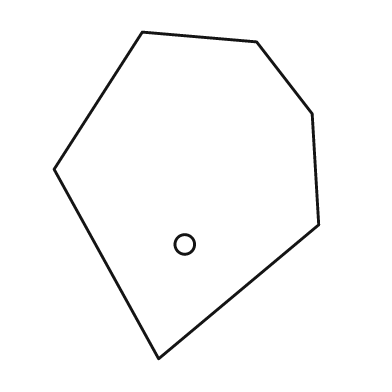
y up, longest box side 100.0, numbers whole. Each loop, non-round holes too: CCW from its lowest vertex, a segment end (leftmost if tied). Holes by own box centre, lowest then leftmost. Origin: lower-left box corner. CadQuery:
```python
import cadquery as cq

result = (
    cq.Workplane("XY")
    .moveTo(32.0, 0.0)
    .lineTo(81.0, 41.0)
    .lineTo(79.0, 75.0)
    .lineTo(62.0, 97.0)
    .lineTo(27.0, 100.0)
    .lineTo(0.0, 58.0)
    .close()
    .moveTo(40.0, 35.0)
    .circle(3.0)
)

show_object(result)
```